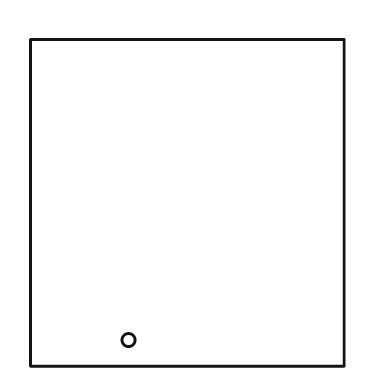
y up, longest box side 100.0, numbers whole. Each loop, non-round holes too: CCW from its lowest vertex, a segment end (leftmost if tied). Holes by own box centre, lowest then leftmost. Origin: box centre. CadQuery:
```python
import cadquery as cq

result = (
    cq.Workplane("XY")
    .moveTo(-48.0, -50.0)
    .lineTo(48.0, -50.0)
    .lineTo(48.0, 50.0)
    .lineTo(-48.0, 50.0)
    .close()
    .moveTo(-18.0, -42.0)
    .circle(2.0)
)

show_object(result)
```